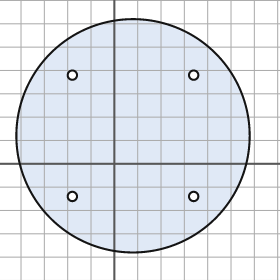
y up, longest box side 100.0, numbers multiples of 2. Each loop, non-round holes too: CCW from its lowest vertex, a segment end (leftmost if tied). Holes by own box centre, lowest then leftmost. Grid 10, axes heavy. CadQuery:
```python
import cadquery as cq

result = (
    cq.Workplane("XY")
    .moveTo(8.0, 12.0)
    .circle(50.0)
    .moveTo(-18.0, -14.0)
    .circle(2.0)
    .moveTo(34.0, -14.0)
    .circle(2.0)
    .moveTo(-18.0, 38.0)
    .circle(2.0)
    .moveTo(34.0, 38.0)
    .circle(2.0)
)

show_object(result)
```